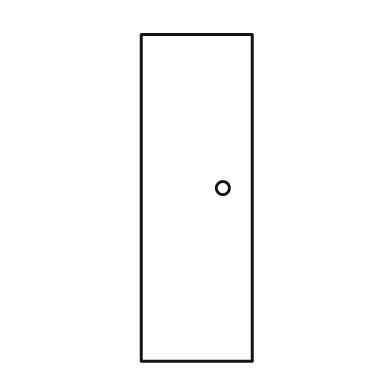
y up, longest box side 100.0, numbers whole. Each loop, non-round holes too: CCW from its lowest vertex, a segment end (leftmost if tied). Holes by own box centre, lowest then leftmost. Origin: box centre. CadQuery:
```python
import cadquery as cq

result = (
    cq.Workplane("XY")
    .moveTo(-17.0, -50.0)
    .lineTo(17.0, -50.0)
    .lineTo(17.0, 50.0)
    .lineTo(-17.0, 50.0)
    .close()
    .moveTo(8.0, 3.0)
    .circle(2.0)
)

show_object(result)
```